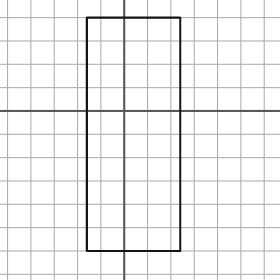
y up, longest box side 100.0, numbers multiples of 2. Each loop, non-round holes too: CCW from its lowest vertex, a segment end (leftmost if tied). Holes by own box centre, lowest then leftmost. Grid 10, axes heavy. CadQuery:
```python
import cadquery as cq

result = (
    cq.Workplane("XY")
    .moveTo(-16.0, -60.0)
    .lineTo(24.0, -60.0)
    .lineTo(24.0, 40.0)
    .lineTo(-16.0, 40.0)
    .close()
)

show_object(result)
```